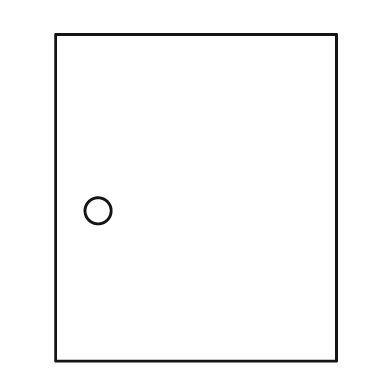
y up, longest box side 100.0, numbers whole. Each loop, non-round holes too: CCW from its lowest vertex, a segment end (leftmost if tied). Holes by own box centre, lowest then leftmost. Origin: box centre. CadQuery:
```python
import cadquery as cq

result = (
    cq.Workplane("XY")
    .moveTo(-43.0, -50.0)
    .lineTo(43.0, -50.0)
    .lineTo(43.0, 50.0)
    .lineTo(-43.0, 50.0)
    .close()
    .moveTo(-30.0, -4.0)
    .circle(4.0)
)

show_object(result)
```